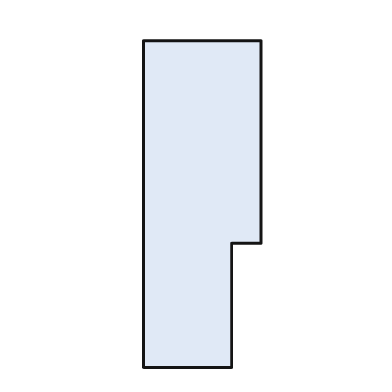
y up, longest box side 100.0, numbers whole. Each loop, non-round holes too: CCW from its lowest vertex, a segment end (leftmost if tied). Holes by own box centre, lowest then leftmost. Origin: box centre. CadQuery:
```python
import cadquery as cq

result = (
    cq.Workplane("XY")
    .moveTo(-18.0, -50.0)
    .lineTo(9.0, -50.0)
    .lineTo(9.0, -12.0)
    .lineTo(18.0, -12.0)
    .lineTo(18.0, 50.0)
    .lineTo(-18.0, 50.0)
    .close()
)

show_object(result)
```